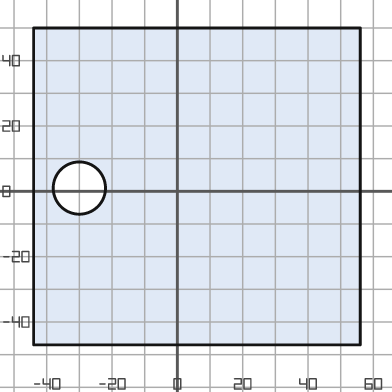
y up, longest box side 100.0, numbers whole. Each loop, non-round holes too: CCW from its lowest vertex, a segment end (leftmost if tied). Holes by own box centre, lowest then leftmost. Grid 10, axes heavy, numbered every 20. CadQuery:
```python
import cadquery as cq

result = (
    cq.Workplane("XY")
    .moveTo(-44.0, -47.0)
    .lineTo(56.0, -47.0)
    .lineTo(56.0, 50.0)
    .lineTo(-44.0, 50.0)
    .close()
    .moveTo(-30.0, 1.0)
    .circle(8.0)
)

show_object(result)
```